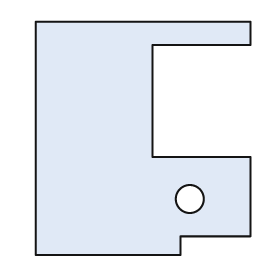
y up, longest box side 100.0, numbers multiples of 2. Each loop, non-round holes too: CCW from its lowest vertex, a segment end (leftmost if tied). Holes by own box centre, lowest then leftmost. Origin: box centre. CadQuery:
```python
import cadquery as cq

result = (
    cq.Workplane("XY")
    .moveTo(-46.0, -50.0)
    .lineTo(16.0, -50.0)
    .lineTo(16.0, -42.0)
    .lineTo(46.0, -42.0)
    .lineTo(46.0, -8.0)
    .lineTo(4.0, -8.0)
    .lineTo(4.0, 40.0)
    .lineTo(46.0, 40.0)
    .lineTo(46.0, 50.0)
    .lineTo(-46.0, 50.0)
    .close()
    .moveTo(20.0, -26.0)
    .circle(6.0)
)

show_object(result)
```